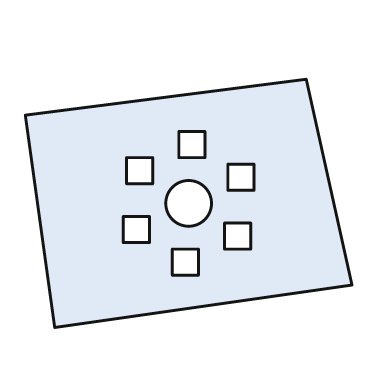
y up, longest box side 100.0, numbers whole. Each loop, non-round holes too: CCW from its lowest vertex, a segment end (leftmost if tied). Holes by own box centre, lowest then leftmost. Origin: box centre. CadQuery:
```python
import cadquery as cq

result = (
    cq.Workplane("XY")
    .moveTo(-41.0, -38.0)
    .lineTo(50.0, -25.0)
    .lineTo(36.0, 38.0)
    .lineTo(-50.0, 27.0)
    .close()
    .moveTo(-5.0, -22.0)
    .lineTo(3.0, -22.0)
    .lineTo(3.0, -14.0)
    .lineTo(-5.0, -14.0)
    .close()
    .moveTo(11.0, -14.0)
    .lineTo(19.0, -14.0)
    .lineTo(19.0, -6.0)
    .lineTo(11.0, -6.0)
    .close()
    .moveTo(-20.0, -12.0)
    .lineTo(-12.0, -12.0)
    .lineTo(-12.0, -4.0)
    .lineTo(-20.0, -4.0)
    .close()
    .moveTo(0.0, 0.0)
    .circle(7.0)
    .moveTo(12.0, 4.0)
    .lineTo(20.0, 4.0)
    .lineTo(20.0, 12.0)
    .lineTo(12.0, 12.0)
    .close()
    .moveTo(-19.0, 6.0)
    .lineTo(-11.0, 6.0)
    .lineTo(-11.0, 14.0)
    .lineTo(-19.0, 14.0)
    .close()
    .moveTo(-3.0, 14.0)
    .lineTo(5.0, 14.0)
    .lineTo(5.0, 22.0)
    .lineTo(-3.0, 22.0)
    .close()
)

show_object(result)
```